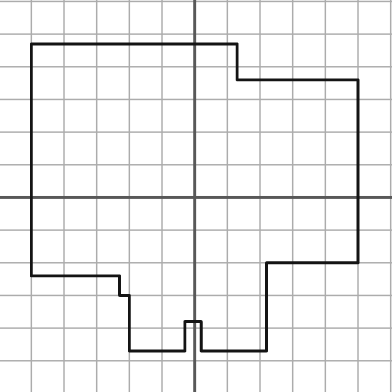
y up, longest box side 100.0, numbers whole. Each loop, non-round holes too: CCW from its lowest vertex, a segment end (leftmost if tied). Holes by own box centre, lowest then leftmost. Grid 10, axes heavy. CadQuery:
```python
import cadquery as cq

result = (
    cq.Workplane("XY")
    .moveTo(-20.0, -47.0)
    .lineTo(-3.0, -47.0)
    .lineTo(-3.0, -38.0)
    .lineTo(2.0, -38.0)
    .lineTo(2.0, -47.0)
    .lineTo(22.0, -47.0)
    .lineTo(22.0, -20.0)
    .lineTo(50.0, -20.0)
    .lineTo(50.0, 36.0)
    .lineTo(13.0, 36.0)
    .lineTo(13.0, 47.0)
    .lineTo(-50.0, 47.0)
    .lineTo(-50.0, -24.0)
    .lineTo(-23.0, -24.0)
    .lineTo(-23.0, -30.0)
    .lineTo(-20.0, -30.0)
    .close()
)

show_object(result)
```